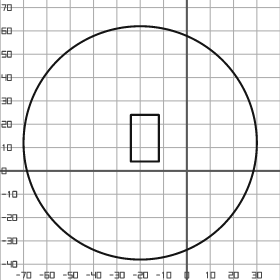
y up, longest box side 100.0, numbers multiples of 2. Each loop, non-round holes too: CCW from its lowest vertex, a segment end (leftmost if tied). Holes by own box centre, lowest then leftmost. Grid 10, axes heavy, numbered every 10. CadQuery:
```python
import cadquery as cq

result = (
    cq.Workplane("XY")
    .moveTo(-20.0, 12.0)
    .circle(50.0)
    .moveTo(-24.0, 4.0)
    .lineTo(-12.0, 4.0)
    .lineTo(-12.0, 24.0)
    .lineTo(-24.0, 24.0)
    .close()
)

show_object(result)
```